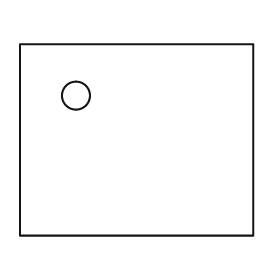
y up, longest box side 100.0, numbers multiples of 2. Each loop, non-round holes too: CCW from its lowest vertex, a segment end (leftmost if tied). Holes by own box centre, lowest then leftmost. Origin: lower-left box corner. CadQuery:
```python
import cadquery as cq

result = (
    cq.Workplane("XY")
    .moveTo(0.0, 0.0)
    .lineTo(100.0, 0.0)
    .lineTo(100.0, 82.0)
    .lineTo(0.0, 82.0)
    .close()
    .moveTo(24.0, 60.0)
    .circle(6.0)
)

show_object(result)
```